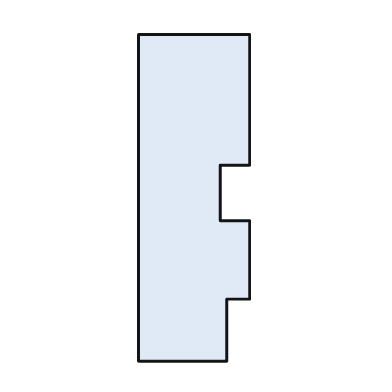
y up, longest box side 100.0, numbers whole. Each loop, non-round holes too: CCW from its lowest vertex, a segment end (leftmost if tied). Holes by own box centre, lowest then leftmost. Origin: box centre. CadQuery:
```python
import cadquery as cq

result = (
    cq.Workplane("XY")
    .moveTo(-17.0, -50.0)
    .lineTo(10.0, -50.0)
    .lineTo(10.0, -31.0)
    .lineTo(17.0, -31.0)
    .lineTo(17.0, -7.0)
    .lineTo(8.0, -7.0)
    .lineTo(8.0, 10.0)
    .lineTo(17.0, 10.0)
    .lineTo(17.0, 50.0)
    .lineTo(-17.0, 50.0)
    .close()
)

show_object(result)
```